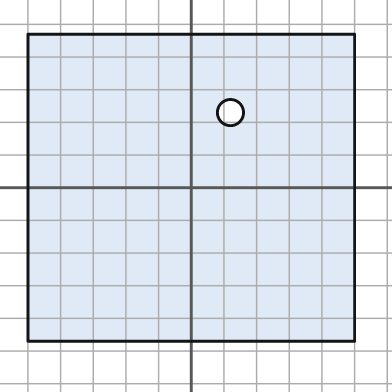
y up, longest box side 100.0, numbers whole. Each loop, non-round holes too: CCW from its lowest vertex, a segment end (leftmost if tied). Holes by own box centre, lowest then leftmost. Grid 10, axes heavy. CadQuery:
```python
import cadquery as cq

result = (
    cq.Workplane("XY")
    .moveTo(-50.0, -47.0)
    .lineTo(50.0, -47.0)
    .lineTo(50.0, 47.0)
    .lineTo(-50.0, 47.0)
    .close()
    .moveTo(12.0, 23.0)
    .circle(4.0)
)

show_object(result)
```